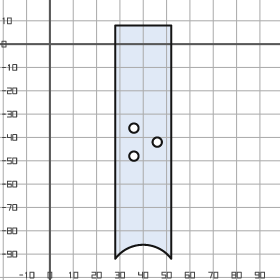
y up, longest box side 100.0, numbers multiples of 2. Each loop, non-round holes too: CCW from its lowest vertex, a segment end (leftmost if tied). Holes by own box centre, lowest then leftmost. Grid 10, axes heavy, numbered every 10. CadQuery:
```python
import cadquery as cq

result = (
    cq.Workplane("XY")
    .moveTo(28.0, -92.0)
    .threePointArc((40.0, -86.0), (52.0, -92.0))
    .lineTo(52.0, 8.0)
    .lineTo(28.0, 8.0)
    .close()
    .moveTo(36.0, -48.0)
    .circle(2.0)
    .moveTo(46.0, -42.0)
    .circle(2.0)
    .moveTo(36.0, -36.0)
    .circle(2.0)
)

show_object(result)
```